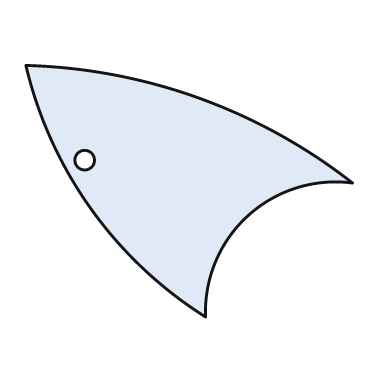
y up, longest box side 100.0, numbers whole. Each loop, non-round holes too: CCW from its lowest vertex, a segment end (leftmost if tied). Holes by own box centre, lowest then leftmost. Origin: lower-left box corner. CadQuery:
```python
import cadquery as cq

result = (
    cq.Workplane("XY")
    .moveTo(55.0, 0.0)
    .threePointArc((68.0, 31.0), (100.0, 41.0))
    .threePointArc((53.0, 67.0), (0.0, 77.0))
    .threePointArc((20.0, 33.0), (55.0, 0.0))
    .close()
    .moveTo(18.0, 48.0)
    .circle(3.0)
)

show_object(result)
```